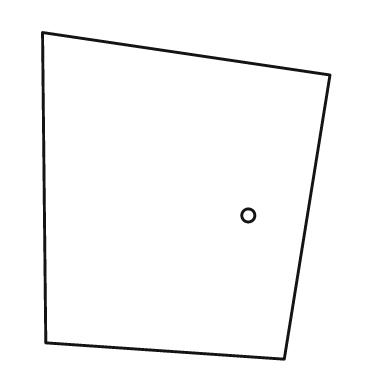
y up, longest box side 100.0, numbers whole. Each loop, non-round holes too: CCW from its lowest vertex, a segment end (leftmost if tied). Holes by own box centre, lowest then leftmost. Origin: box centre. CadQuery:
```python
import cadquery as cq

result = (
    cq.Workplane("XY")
    .moveTo(30.0, -50.0)
    .lineTo(44.0, 37.0)
    .lineTo(-44.0, 50.0)
    .lineTo(-43.0, -45.0)
    .close()
    .moveTo(19.0, -6.0)
    .circle(2.0)
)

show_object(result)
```